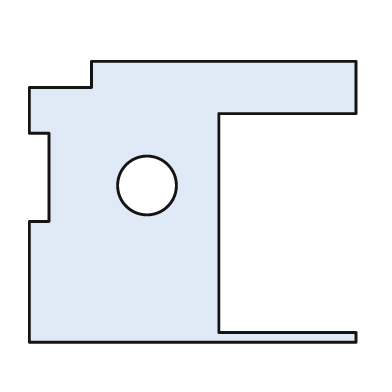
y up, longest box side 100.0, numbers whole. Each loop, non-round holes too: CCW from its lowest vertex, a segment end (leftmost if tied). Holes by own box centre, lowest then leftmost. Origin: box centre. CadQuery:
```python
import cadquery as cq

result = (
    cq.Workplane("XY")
    .moveTo(-50.0, -43.0)
    .lineTo(50.0, -43.0)
    .lineTo(50.0, -40.0)
    .lineTo(8.0, -40.0)
    .lineTo(8.0, 27.0)
    .lineTo(50.0, 27.0)
    .lineTo(50.0, 43.0)
    .lineTo(-31.0, 43.0)
    .lineTo(-31.0, 35.0)
    .lineTo(-50.0, 35.0)
    .lineTo(-50.0, 21.0)
    .lineTo(-44.0, 21.0)
    .lineTo(-44.0, -6.0)
    .lineTo(-50.0, -6.0)
    .close()
    .moveTo(-14.0, 5.0)
    .circle(9.0)
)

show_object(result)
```